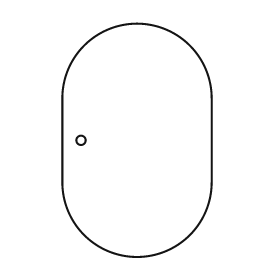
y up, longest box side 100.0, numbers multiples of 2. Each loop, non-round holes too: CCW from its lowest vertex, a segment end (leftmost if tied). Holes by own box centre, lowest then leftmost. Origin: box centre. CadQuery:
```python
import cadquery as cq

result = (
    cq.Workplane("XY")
    .moveTo(-32.0, -18.0)
    .threePointArc((0.0, -50.0), (32.0, -18.0))
    .lineTo(32.0, 18.0)
    .threePointArc((0.0, 50.0), (-32.0, 18.0))
    .close()
    .moveTo(-24.0, 0.0)
    .circle(2.0)
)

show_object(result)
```